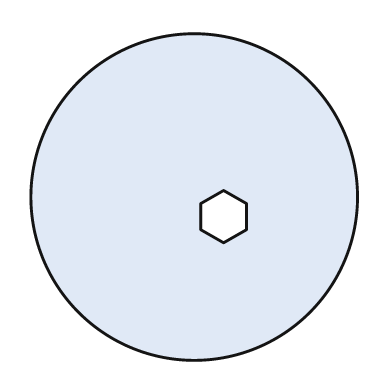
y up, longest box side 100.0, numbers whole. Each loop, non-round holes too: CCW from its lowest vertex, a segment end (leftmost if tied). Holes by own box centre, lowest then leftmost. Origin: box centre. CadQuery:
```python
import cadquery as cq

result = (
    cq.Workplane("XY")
    .moveTo(0.0, 0.0)
    .circle(50.0)
    .moveTo(9.0, -14.0)
    .lineTo(16.0, -10.0)
    .lineTo(16.0, -2.0)
    .lineTo(9.0, 2.0)
    .lineTo(2.0, -2.0)
    .lineTo(2.0, -10.0)
    .close()
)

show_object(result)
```